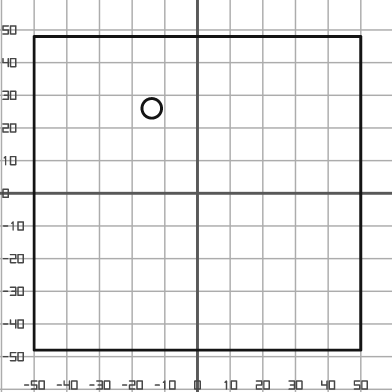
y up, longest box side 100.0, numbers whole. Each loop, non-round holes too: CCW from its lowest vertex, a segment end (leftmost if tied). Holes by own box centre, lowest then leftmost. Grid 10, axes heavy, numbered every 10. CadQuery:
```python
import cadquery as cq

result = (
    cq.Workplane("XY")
    .moveTo(-50.0, -48.0)
    .lineTo(50.0, -48.0)
    .lineTo(50.0, 48.0)
    .lineTo(-50.0, 48.0)
    .close()
    .moveTo(-14.0, 26.0)
    .circle(3.0)
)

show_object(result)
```